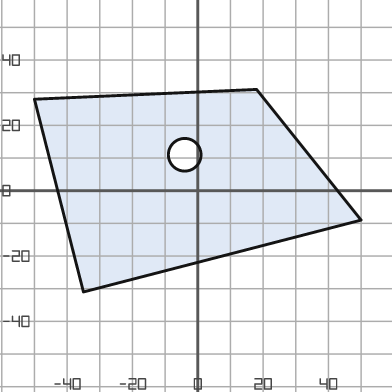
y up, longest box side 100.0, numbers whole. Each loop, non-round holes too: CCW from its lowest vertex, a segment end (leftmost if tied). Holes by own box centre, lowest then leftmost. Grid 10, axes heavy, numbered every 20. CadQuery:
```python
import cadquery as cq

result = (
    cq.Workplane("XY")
    .moveTo(-35.0, -31.0)
    .lineTo(50.0, -9.0)
    .lineTo(18.0, 31.0)
    .lineTo(-50.0, 28.0)
    .close()
    .moveTo(-4.0, 11.0)
    .circle(5.0)
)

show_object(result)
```